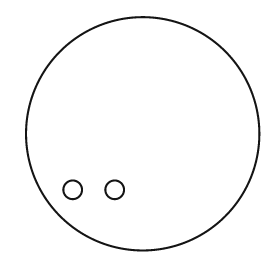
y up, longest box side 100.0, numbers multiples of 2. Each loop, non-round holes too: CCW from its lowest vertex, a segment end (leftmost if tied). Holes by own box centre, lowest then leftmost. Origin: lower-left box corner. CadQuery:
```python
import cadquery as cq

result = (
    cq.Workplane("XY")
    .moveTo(50.0, 50.0)
    .circle(50.0)
    .moveTo(20.0, 26.0)
    .circle(4.0)
    .moveTo(38.0, 26.0)
    .circle(4.0)
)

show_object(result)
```